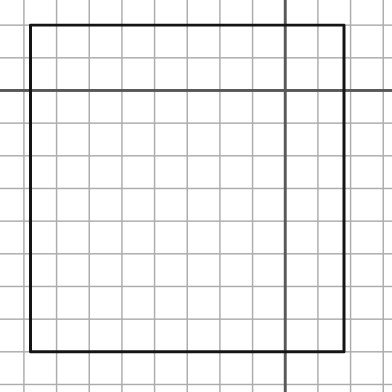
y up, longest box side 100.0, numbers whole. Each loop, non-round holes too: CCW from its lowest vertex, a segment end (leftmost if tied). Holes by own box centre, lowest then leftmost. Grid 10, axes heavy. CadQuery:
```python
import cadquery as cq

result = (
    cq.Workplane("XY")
    .moveTo(-78.0, -80.0)
    .lineTo(18.0, -80.0)
    .lineTo(18.0, 20.0)
    .lineTo(-78.0, 20.0)
    .close()
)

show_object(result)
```